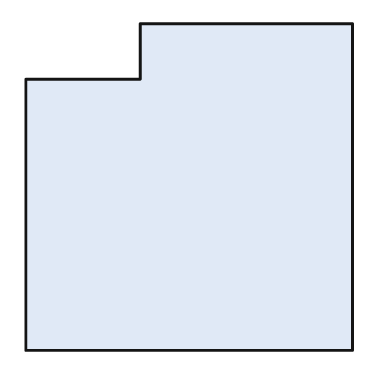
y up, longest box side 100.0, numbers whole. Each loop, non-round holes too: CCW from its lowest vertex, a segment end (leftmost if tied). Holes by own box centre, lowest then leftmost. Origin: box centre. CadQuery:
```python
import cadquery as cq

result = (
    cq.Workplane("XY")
    .moveTo(-50.0, -50.0)
    .lineTo(50.0, -50.0)
    .lineTo(50.0, 50.0)
    .lineTo(-15.0, 50.0)
    .lineTo(-15.0, 33.0)
    .lineTo(-50.0, 33.0)
    .close()
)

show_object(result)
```